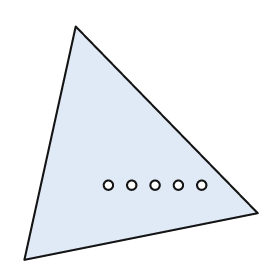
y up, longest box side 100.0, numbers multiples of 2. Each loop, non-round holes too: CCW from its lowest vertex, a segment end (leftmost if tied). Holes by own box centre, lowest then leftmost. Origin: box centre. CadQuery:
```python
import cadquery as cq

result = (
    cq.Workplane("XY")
    .moveTo(-50.0, -50.0)
    .lineTo(50.0, -30.0)
    .lineTo(-28.0, 50.0)
    .close()
    .moveTo(-14.0, -18.0)
    .circle(2.0)
    .moveTo(-4.0, -18.0)
    .circle(2.0)
    .moveTo(6.0, -18.0)
    .circle(2.0)
    .moveTo(16.0, -18.0)
    .circle(2.0)
    .moveTo(26.0, -18.0)
    .circle(2.0)
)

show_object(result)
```